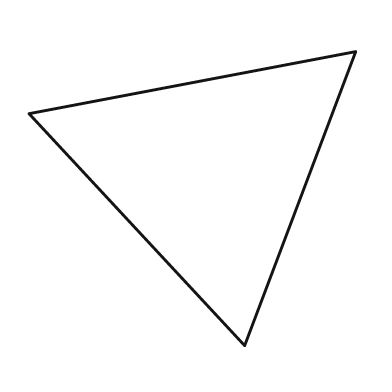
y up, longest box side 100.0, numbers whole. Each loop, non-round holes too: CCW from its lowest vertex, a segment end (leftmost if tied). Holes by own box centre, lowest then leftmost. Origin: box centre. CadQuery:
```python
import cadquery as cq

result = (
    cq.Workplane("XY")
    .moveTo(16.0, -45.0)
    .lineTo(50.0, 45.0)
    .lineTo(-50.0, 26.0)
    .close()
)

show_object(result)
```